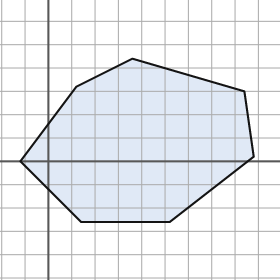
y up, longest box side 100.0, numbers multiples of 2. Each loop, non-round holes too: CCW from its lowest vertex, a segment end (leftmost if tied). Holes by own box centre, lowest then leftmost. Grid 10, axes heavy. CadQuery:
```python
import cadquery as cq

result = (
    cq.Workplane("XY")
    .moveTo(14.0, -26.0)
    .lineTo(52.0, -26.0)
    .lineTo(88.0, 2.0)
    .lineTo(84.0, 30.0)
    .lineTo(36.0, 44.0)
    .lineTo(12.0, 32.0)
    .lineTo(-12.0, 0.0)
    .close()
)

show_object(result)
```